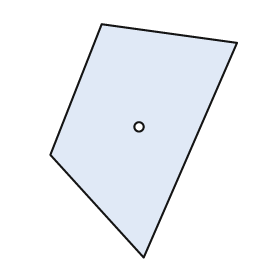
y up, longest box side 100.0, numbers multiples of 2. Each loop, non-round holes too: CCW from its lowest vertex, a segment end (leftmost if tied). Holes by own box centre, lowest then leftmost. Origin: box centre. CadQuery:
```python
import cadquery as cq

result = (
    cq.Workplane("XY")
    .moveTo(0.0, -50.0)
    .lineTo(40.0, 42.0)
    .lineTo(-18.0, 50.0)
    .lineTo(-40.0, -6.0)
    .close()
    .moveTo(-2.0, 6.0)
    .circle(2.0)
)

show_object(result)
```